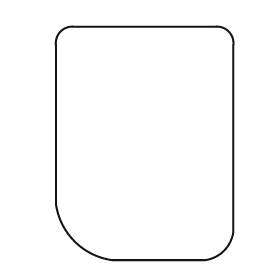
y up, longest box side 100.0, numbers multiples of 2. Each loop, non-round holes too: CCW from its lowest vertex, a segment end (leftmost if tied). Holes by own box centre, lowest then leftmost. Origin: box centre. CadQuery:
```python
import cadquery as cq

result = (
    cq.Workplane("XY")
    .moveTo(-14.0, -50.0)
    .lineTo(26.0, -50.0)
    .threePointArc((34.0, -46.0), (38.0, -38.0))
    .lineTo(38.0, 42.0)
    .threePointArc((36.0, 48.0), (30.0, 50.0))
    .lineTo(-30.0, 50.0)
    .threePointArc((-36.0, 48.0), (-38.0, 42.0))
    .lineTo(-38.0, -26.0)
    .threePointArc((-30.0, -42.0), (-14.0, -50.0))
    .close()
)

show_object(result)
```